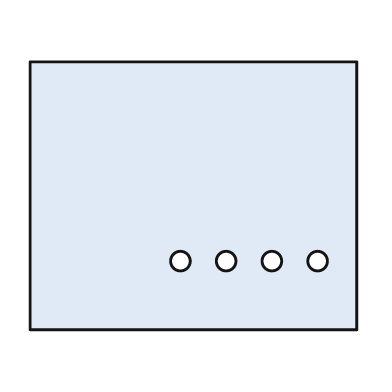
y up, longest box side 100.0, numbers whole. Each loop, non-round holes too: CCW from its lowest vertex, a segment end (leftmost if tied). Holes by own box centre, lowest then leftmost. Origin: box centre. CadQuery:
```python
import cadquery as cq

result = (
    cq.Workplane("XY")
    .moveTo(-50.0, -41.0)
    .lineTo(50.0, -41.0)
    .lineTo(50.0, 41.0)
    .lineTo(-50.0, 41.0)
    .close()
    .moveTo(-4.0, -20.0)
    .circle(3.0)
    .moveTo(10.0, -20.0)
    .circle(3.0)
    .moveTo(24.0, -20.0)
    .circle(3.0)
    .moveTo(38.0, -20.0)
    .circle(3.0)
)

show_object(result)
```